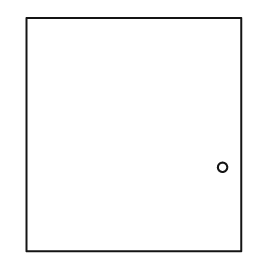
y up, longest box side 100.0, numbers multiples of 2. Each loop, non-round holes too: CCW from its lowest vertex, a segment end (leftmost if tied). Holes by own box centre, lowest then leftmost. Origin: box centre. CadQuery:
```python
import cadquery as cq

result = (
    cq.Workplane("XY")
    .moveTo(-46.0, -50.0)
    .lineTo(46.0, -50.0)
    .lineTo(46.0, 50.0)
    .lineTo(-46.0, 50.0)
    .close()
    .moveTo(38.0, -14.0)
    .circle(2.0)
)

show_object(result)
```